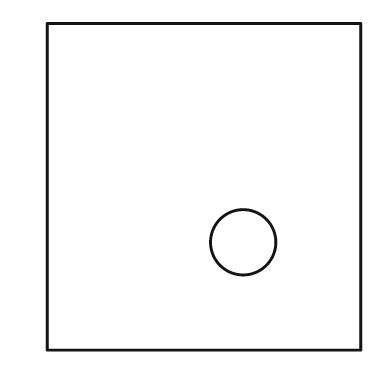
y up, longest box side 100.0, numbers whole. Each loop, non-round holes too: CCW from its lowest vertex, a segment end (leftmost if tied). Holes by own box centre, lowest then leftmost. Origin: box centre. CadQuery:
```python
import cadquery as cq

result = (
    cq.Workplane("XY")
    .moveTo(-48.0, -50.0)
    .lineTo(48.0, -50.0)
    .lineTo(48.0, 50.0)
    .lineTo(-48.0, 50.0)
    .close()
    .moveTo(12.0, -17.0)
    .circle(10.0)
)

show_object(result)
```